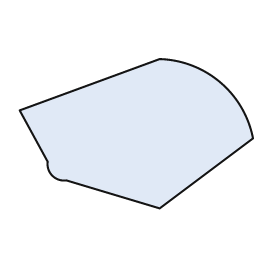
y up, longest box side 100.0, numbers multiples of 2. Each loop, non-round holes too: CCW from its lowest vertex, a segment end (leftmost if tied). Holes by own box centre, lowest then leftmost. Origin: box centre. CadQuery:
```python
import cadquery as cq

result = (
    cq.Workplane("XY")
    .moveTo(10.0, -32.0)
    .lineTo(50.0, -2.0)
    .threePointArc((36.0, 22.0), (10.0, 32.0))
    .lineTo(-50.0, 10.0)
    .lineTo(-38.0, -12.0)
    .threePointArc((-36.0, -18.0), (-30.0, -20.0))
    .close()
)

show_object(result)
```